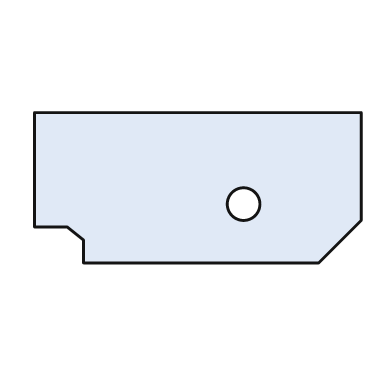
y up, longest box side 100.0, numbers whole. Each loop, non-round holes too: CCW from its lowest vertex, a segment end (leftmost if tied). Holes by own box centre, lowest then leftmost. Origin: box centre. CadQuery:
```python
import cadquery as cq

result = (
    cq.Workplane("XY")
    .moveTo(-35.0, -23.0)
    .lineTo(37.0, -23.0)
    .lineTo(50.0, -10.0)
    .lineTo(50.0, 23.0)
    .lineTo(-50.0, 23.0)
    .lineTo(-50.0, -12.0)
    .lineTo(-40.0, -12.0)
    .lineTo(-35.0, -16.0)
    .close()
    .moveTo(14.0, -5.0)
    .circle(5.0)
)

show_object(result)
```